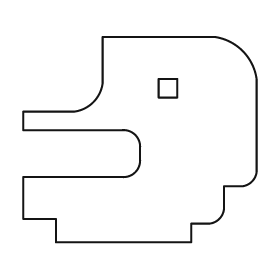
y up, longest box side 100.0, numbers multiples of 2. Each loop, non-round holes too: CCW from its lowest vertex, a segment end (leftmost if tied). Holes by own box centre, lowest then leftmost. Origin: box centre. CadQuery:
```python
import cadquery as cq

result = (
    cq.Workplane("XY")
    .moveTo(-36.0, -44.0)
    .lineTo(22.0, -44.0)
    .lineTo(22.0, -36.0)
    .lineTo(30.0, -36.0)
    .threePointArc((34.0, -34.0), (36.0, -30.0))
    .lineTo(36.0, -20.0)
    .lineTo(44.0, -20.0)
    .threePointArc((48.0, -18.0), (50.0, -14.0))
    .lineTo(50.0, 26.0)
    .threePointArc((44.0, 38.0), (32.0, 44.0))
    .lineTo(-16.0, 44.0)
    .lineTo(-16.0, 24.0)
    .threePointArc((-20.0, 16.0), (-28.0, 12.0))
    .lineTo(-50.0, 12.0)
    .lineTo(-50.0, 4.0)
    .lineTo(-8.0, 4.0)
    .threePointArc((-2.0, 2.0), (0.0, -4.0))
    .lineTo(0.0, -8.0)
    .threePointArc((-2.0, -14.0), (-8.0, -16.0))
    .lineTo(-50.0, -16.0)
    .lineTo(-50.0, -34.0)
    .lineTo(-36.0, -34.0)
    .close()
    .moveTo(8.0, 18.0)
    .lineTo(16.0, 18.0)
    .lineTo(16.0, 26.0)
    .lineTo(8.0, 26.0)
    .close()
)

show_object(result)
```